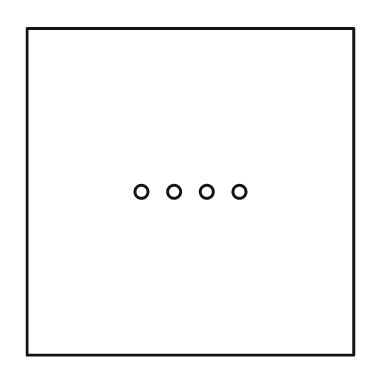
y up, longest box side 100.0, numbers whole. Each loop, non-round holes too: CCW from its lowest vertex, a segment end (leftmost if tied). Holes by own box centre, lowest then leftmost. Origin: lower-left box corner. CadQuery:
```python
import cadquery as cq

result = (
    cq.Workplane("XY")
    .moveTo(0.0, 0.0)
    .lineTo(100.0, 0.0)
    .lineTo(100.0, 100.0)
    .lineTo(0.0, 100.0)
    .close()
    .moveTo(35.0, 50.0)
    .circle(2.0)
    .moveTo(45.0, 50.0)
    .circle(2.0)
    .moveTo(55.0, 50.0)
    .circle(2.0)
    .moveTo(65.0, 50.0)
    .circle(2.0)
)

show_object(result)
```